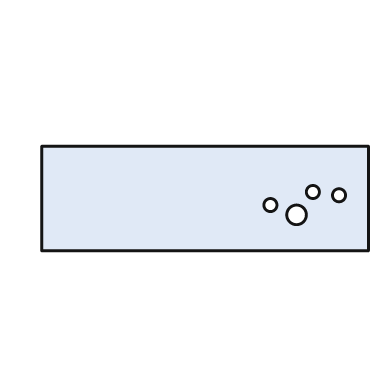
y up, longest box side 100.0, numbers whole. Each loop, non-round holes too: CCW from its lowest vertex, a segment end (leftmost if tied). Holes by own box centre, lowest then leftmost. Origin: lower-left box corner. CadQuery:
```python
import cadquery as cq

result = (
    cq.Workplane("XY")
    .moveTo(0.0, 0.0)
    .lineTo(100.0, 0.0)
    .lineTo(100.0, 32.0)
    .lineTo(0.0, 32.0)
    .close()
    .moveTo(78.0, 11.0)
    .circle(3.0)
    .moveTo(70.0, 14.0)
    .circle(2.0)
    .moveTo(91.0, 17.0)
    .circle(2.0)
    .moveTo(83.0, 18.0)
    .circle(2.0)
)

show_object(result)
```